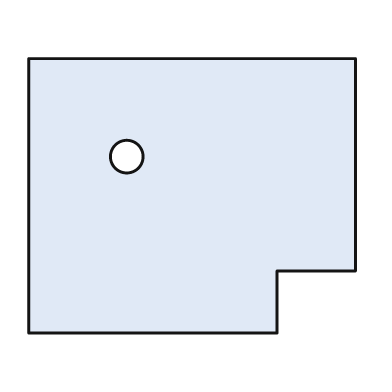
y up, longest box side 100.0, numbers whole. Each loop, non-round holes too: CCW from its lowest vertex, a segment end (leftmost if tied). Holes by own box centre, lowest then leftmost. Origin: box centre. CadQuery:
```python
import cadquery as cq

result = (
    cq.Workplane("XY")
    .moveTo(-50.0, -42.0)
    .lineTo(26.0, -42.0)
    .lineTo(26.0, -23.0)
    .lineTo(50.0, -23.0)
    .lineTo(50.0, 42.0)
    .lineTo(-50.0, 42.0)
    .close()
    .moveTo(-20.0, 12.0)
    .circle(5.0)
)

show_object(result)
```